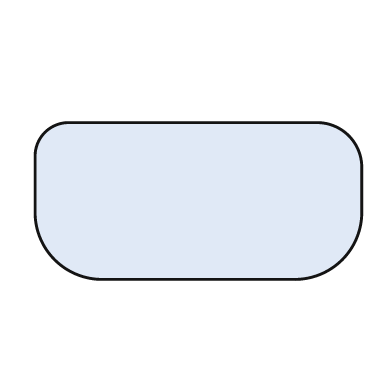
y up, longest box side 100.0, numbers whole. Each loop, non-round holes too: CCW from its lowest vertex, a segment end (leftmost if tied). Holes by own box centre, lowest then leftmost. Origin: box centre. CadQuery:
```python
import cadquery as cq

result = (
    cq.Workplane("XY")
    .moveTo(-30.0, -24.0)
    .lineTo(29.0, -24.0)
    .threePointArc((44.0, -18.0), (50.0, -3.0))
    .lineTo(50.0, 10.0)
    .threePointArc((46.0, 20.0), (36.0, 24.0))
    .lineTo(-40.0, 24.0)
    .threePointArc((-47.0, 21.0), (-50.0, 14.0))
    .lineTo(-50.0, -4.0)
    .threePointArc((-44.0, -18.0), (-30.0, -24.0))
    .close()
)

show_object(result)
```